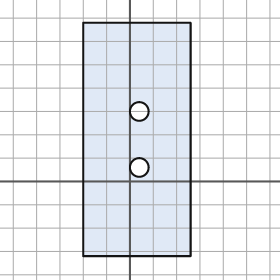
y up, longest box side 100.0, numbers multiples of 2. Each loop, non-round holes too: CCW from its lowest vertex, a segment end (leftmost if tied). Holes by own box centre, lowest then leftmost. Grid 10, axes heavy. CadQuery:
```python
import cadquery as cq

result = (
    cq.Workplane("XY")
    .moveTo(-20.0, -32.0)
    .lineTo(26.0, -32.0)
    .lineTo(26.0, 68.0)
    .lineTo(-20.0, 68.0)
    .close()
    .moveTo(4.0, 6.0)
    .circle(4.0)
    .moveTo(4.0, 30.0)
    .circle(4.0)
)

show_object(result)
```